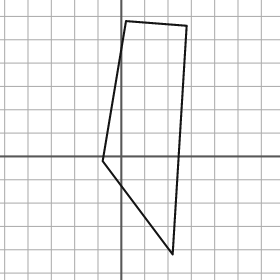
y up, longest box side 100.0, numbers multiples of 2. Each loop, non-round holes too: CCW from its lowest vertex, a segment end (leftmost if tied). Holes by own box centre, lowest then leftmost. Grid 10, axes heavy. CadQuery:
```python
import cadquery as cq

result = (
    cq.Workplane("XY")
    .moveTo(22.0, -42.0)
    .lineTo(28.0, 56.0)
    .lineTo(2.0, 58.0)
    .lineTo(-8.0, -2.0)
    .close()
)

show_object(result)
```